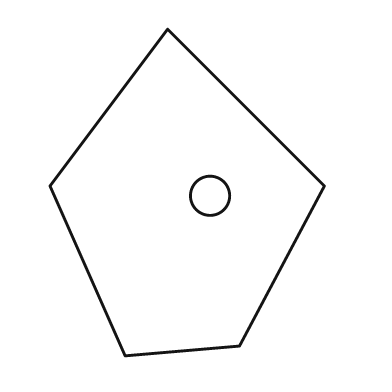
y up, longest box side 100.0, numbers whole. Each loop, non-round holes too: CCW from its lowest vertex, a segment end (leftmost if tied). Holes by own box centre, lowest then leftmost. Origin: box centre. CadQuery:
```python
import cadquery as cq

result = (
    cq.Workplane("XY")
    .moveTo(-19.0, -50.0)
    .lineTo(16.0, -47.0)
    .lineTo(42.0, 2.0)
    .lineTo(-6.0, 50.0)
    .lineTo(-42.0, 2.0)
    .close()
    .moveTo(7.0, -1.0)
    .circle(6.0)
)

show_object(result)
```